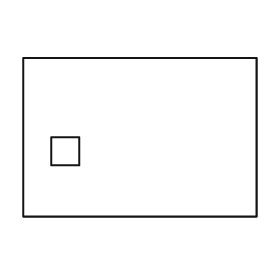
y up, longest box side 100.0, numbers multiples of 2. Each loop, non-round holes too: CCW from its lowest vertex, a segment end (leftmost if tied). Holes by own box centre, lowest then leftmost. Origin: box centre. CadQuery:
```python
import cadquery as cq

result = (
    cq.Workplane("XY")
    .moveTo(-50.0, -34.0)
    .lineTo(50.0, -34.0)
    .lineTo(50.0, 34.0)
    .lineTo(-50.0, 34.0)
    .close()
    .moveTo(-38.0, -12.0)
    .lineTo(-26.0, -12.0)
    .lineTo(-26.0, 0.0)
    .lineTo(-38.0, 0.0)
    .close()
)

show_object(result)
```